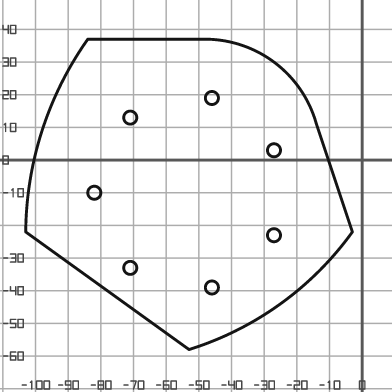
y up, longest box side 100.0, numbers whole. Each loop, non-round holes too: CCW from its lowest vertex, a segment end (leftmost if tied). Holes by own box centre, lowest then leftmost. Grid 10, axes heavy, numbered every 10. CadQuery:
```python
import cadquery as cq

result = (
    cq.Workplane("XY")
    .moveTo(-53.0, -58.0)
    .threePointArc((-25.0, -44.0), (-3.0, -22.0))
    .lineTo(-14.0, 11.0)
    .threePointArc((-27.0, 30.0), (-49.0, 37.0))
    .lineTo(-84.0, 37.0)
    .threePointArc((-98.0, 9.0), (-103.0, -22.0))
    .close()
    .moveTo(-46.0, -39.0)
    .circle(2.0)
    .moveTo(-71.0, -33.0)
    .circle(2.0)
    .moveTo(-27.0, -23.0)
    .circle(2.0)
    .moveTo(-82.0, -10.0)
    .circle(2.0)
    .moveTo(-27.0, 3.0)
    .circle(2.0)
    .moveTo(-71.0, 13.0)
    .circle(2.0)
    .moveTo(-46.0, 19.0)
    .circle(2.0)
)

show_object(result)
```